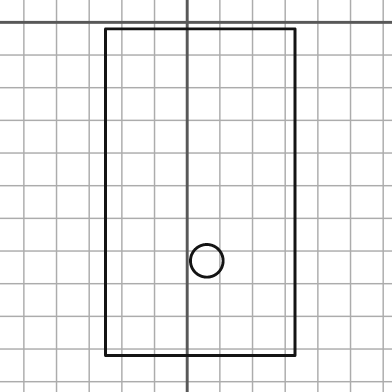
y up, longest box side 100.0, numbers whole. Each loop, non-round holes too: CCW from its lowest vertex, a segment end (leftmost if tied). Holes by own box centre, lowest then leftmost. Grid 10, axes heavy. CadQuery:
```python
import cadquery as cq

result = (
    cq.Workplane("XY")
    .moveTo(-25.0, -102.0)
    .lineTo(33.0, -102.0)
    .lineTo(33.0, -2.0)
    .lineTo(-25.0, -2.0)
    .close()
    .moveTo(6.0, -73.0)
    .circle(5.0)
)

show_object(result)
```